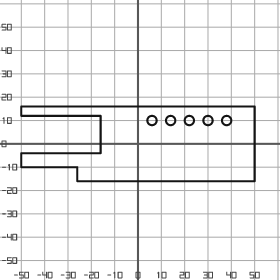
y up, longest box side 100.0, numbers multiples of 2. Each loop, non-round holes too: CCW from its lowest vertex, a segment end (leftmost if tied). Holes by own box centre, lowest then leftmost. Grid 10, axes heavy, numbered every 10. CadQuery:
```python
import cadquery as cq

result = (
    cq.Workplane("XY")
    .moveTo(-26.0, -16.0)
    .lineTo(50.0, -16.0)
    .lineTo(50.0, 16.0)
    .lineTo(-50.0, 16.0)
    .lineTo(-50.0, 12.0)
    .lineTo(-16.0, 12.0)
    .lineTo(-16.0, -4.0)
    .lineTo(-50.0, -4.0)
    .lineTo(-50.0, -10.0)
    .lineTo(-26.0, -10.0)
    .close()
    .moveTo(6.0, 10.0)
    .circle(2.0)
    .moveTo(14.0, 10.0)
    .circle(2.0)
    .moveTo(22.0, 10.0)
    .circle(2.0)
    .moveTo(30.0, 10.0)
    .circle(2.0)
    .moveTo(38.0, 10.0)
    .circle(2.0)
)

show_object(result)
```